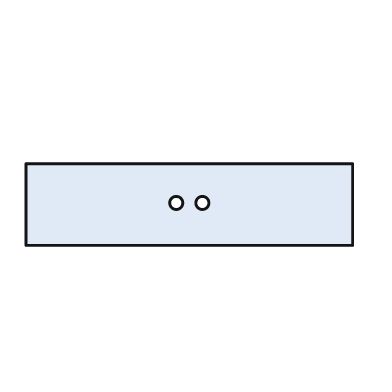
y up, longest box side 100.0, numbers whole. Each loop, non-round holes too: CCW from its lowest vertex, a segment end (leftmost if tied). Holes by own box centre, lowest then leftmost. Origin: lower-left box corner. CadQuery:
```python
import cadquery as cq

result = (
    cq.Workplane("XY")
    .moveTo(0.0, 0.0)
    .lineTo(100.0, 0.0)
    .lineTo(100.0, 25.0)
    .lineTo(0.0, 25.0)
    .close()
    .moveTo(46.0, 13.0)
    .circle(2.0)
    .moveTo(54.0, 13.0)
    .circle(2.0)
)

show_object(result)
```